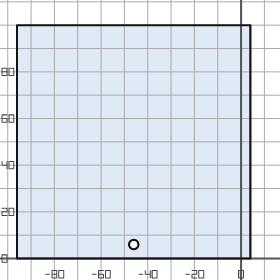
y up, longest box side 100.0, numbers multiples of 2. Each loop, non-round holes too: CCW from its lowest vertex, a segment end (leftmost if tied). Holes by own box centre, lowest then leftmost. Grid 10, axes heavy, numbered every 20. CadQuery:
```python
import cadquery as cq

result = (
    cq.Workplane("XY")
    .moveTo(-96.0, 0.0)
    .lineTo(4.0, 0.0)
    .lineTo(4.0, 100.0)
    .lineTo(-96.0, 100.0)
    .close()
    .moveTo(-46.0, 6.0)
    .circle(2.0)
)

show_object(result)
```